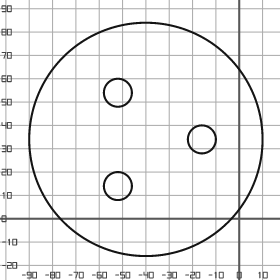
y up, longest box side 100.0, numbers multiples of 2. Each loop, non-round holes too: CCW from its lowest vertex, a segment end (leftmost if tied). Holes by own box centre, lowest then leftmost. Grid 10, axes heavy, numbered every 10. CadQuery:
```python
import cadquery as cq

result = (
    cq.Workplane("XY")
    .moveTo(-40.0, 34.0)
    .circle(50.0)
    .moveTo(-52.0, 14.0)
    .circle(6.0)
    .moveTo(-16.0, 34.0)
    .circle(6.0)
    .moveTo(-52.0, 54.0)
    .circle(6.0)
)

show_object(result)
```